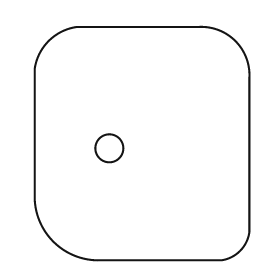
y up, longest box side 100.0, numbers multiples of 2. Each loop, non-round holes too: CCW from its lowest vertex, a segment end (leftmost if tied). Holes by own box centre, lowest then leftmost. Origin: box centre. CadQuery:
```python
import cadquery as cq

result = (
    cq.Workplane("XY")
    .moveTo(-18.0, -50.0)
    .lineTo(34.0, -50.0)
    .threePointArc((42.0, -46.0), (46.0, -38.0))
    .lineTo(46.0, 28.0)
    .threePointArc((40.0, 44.0), (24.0, 50.0))
    .lineTo(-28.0, 50.0)
    .threePointArc((-40.0, 44.0), (-46.0, 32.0))
    .lineTo(-46.0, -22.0)
    .threePointArc((-38.0, -42.0), (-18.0, -50.0))
    .close()
    .moveTo(-14.0, -2.0)
    .circle(6.0)
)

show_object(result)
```